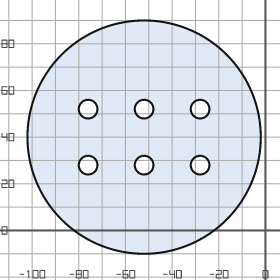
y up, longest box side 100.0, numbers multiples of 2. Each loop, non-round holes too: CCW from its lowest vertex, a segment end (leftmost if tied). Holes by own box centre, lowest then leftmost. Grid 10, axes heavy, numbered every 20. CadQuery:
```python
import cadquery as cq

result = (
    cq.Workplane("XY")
    .moveTo(-52.0, 40.0)
    .circle(50.0)
    .moveTo(-76.0, 28.0)
    .circle(4.0)
    .moveTo(-52.0, 28.0)
    .circle(4.0)
    .moveTo(-28.0, 28.0)
    .circle(4.0)
    .moveTo(-76.0, 52.0)
    .circle(4.0)
    .moveTo(-52.0, 52.0)
    .circle(4.0)
    .moveTo(-28.0, 52.0)
    .circle(4.0)
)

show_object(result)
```